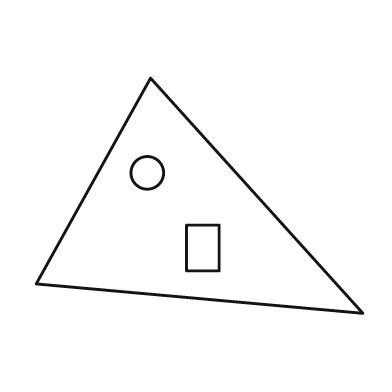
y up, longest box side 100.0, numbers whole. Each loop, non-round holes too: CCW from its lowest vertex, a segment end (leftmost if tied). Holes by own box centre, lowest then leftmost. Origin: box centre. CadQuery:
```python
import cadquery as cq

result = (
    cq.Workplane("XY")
    .moveTo(50.0, -36.0)
    .lineTo(-15.0, 36.0)
    .lineTo(-50.0, -27.0)
    .close()
    .moveTo(-4.0, -23.0)
    .lineTo(6.0, -23.0)
    .lineTo(6.0, -9.0)
    .lineTo(-4.0, -9.0)
    .close()
    .moveTo(-16.0, 7.0)
    .circle(5.0)
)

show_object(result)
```